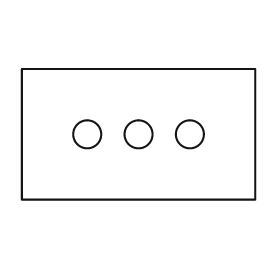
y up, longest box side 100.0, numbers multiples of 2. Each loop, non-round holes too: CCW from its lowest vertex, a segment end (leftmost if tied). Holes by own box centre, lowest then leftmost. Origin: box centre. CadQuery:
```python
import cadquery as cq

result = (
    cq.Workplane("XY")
    .moveTo(-50.0, -28.0)
    .lineTo(50.0, -28.0)
    .lineTo(50.0, 28.0)
    .lineTo(-50.0, 28.0)
    .close()
    .moveTo(-22.0, 0.0)
    .circle(6.0)
    .moveTo(0.0, 0.0)
    .circle(6.0)
    .moveTo(22.0, 0.0)
    .circle(6.0)
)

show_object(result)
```